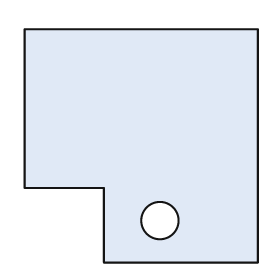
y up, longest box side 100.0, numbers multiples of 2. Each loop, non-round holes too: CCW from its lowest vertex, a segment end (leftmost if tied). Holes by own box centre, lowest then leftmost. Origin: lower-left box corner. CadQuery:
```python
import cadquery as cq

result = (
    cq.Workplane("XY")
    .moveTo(34.0, 0.0)
    .lineTo(100.0, 0.0)
    .lineTo(100.0, 100.0)
    .lineTo(0.0, 100.0)
    .lineTo(0.0, 32.0)
    .lineTo(34.0, 32.0)
    .close()
    .moveTo(58.0, 18.0)
    .circle(8.0)
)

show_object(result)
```